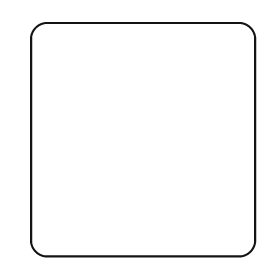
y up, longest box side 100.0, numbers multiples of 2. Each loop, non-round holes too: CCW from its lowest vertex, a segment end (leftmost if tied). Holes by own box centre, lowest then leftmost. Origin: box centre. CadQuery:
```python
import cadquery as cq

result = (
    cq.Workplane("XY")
    .moveTo(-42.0, -50.0)
    .lineTo(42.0, -50.0)
    .threePointArc((46.0, -48.0), (48.0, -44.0))
    .lineTo(48.0, 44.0)
    .threePointArc((46.0, 48.0), (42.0, 50.0))
    .lineTo(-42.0, 50.0)
    .threePointArc((-46.0, 48.0), (-48.0, 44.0))
    .lineTo(-48.0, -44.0)
    .threePointArc((-46.0, -48.0), (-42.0, -50.0))
    .close()
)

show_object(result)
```